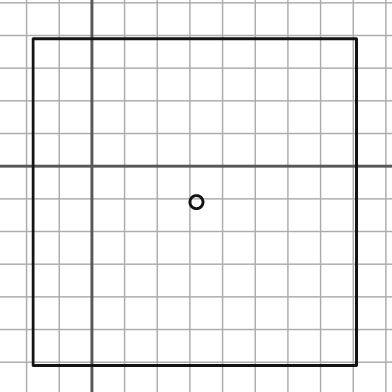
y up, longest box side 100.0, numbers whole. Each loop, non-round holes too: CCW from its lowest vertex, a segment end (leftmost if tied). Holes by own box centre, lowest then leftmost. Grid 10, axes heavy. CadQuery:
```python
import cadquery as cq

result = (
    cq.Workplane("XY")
    .moveTo(-18.0, -61.0)
    .lineTo(81.0, -61.0)
    .lineTo(81.0, 39.0)
    .lineTo(-18.0, 39.0)
    .close()
    .moveTo(32.0, -11.0)
    .circle(2.0)
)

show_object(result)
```